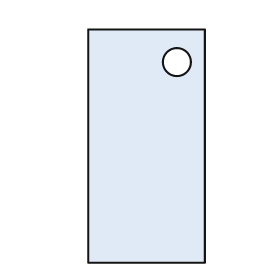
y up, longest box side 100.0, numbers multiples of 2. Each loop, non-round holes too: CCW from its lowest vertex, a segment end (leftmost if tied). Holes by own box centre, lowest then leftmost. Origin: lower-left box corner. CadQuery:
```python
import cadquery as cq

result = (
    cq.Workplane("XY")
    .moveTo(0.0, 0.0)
    .lineTo(50.0, 0.0)
    .lineTo(50.0, 100.0)
    .lineTo(0.0, 100.0)
    .close()
    .moveTo(38.0, 86.0)
    .circle(6.0)
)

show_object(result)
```